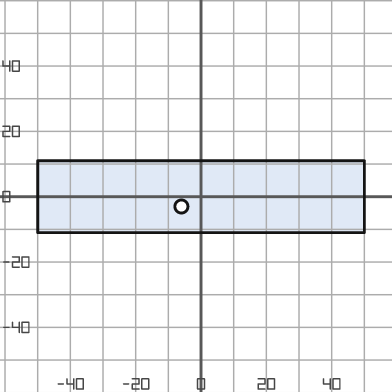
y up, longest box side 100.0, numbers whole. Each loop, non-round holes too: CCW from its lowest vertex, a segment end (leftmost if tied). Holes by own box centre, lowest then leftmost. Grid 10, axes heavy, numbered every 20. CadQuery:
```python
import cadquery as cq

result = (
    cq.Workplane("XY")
    .moveTo(-50.0, -11.0)
    .lineTo(50.0, -11.0)
    .lineTo(50.0, 11.0)
    .lineTo(-50.0, 11.0)
    .close()
    .moveTo(-6.0, -3.0)
    .circle(2.0)
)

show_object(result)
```